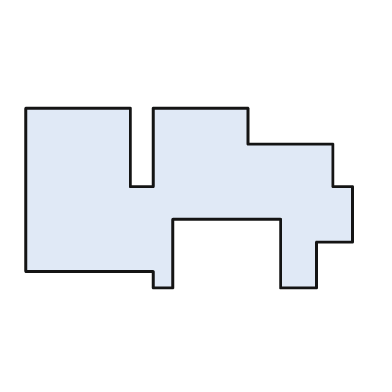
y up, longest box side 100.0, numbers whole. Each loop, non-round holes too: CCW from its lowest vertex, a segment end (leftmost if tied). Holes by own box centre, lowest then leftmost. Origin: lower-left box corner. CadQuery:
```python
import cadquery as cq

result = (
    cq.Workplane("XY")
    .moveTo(39.0, 0.0)
    .lineTo(45.0, 0.0)
    .lineTo(45.0, 21.0)
    .lineTo(78.0, 21.0)
    .lineTo(78.0, 0.0)
    .lineTo(89.0, 0.0)
    .lineTo(89.0, 14.0)
    .lineTo(100.0, 14.0)
    .lineTo(100.0, 31.0)
    .lineTo(94.0, 31.0)
    .lineTo(94.0, 44.0)
    .lineTo(68.0, 44.0)
    .lineTo(68.0, 55.0)
    .lineTo(39.0, 55.0)
    .lineTo(39.0, 31.0)
    .lineTo(32.0, 31.0)
    .lineTo(32.0, 55.0)
    .lineTo(0.0, 55.0)
    .lineTo(0.0, 5.0)
    .lineTo(39.0, 5.0)
    .close()
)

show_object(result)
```